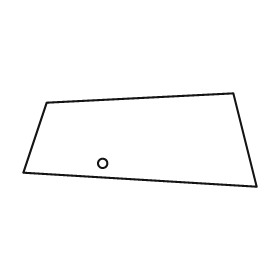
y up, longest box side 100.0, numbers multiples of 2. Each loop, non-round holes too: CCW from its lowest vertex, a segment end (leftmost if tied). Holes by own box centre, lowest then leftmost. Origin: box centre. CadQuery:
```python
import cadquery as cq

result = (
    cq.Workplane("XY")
    .moveTo(50.0, -20.0)
    .lineTo(40.0, 20.0)
    .lineTo(-40.0, 16.0)
    .lineTo(-50.0, -14.0)
    .close()
    .moveTo(-16.0, -10.0)
    .circle(2.0)
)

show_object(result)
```